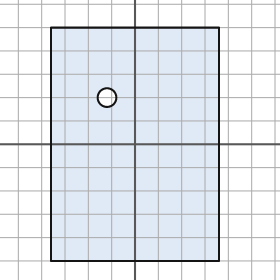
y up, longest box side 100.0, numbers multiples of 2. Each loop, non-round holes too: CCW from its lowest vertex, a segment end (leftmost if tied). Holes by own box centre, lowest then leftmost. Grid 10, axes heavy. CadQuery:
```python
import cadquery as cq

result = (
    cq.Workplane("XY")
    .moveTo(-36.0, -50.0)
    .lineTo(36.0, -50.0)
    .lineTo(36.0, 50.0)
    .lineTo(-36.0, 50.0)
    .close()
    .moveTo(-12.0, 20.0)
    .circle(4.0)
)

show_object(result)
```